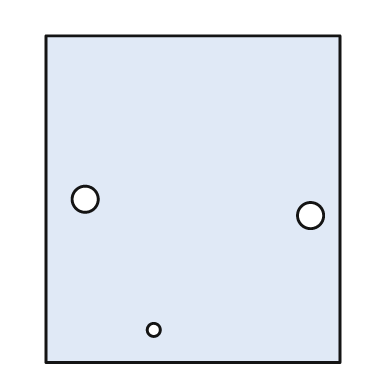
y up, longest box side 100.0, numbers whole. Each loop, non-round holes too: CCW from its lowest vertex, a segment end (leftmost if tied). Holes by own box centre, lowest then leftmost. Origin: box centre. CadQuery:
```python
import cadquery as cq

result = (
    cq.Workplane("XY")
    .moveTo(-45.0, -50.0)
    .lineTo(45.0, -50.0)
    .lineTo(45.0, 50.0)
    .lineTo(-45.0, 50.0)
    .close()
    .moveTo(-12.0, -40.0)
    .circle(2.0)
    .moveTo(36.0, -5.0)
    .circle(4.0)
    .moveTo(-33.0, 0.0)
    .circle(4.0)
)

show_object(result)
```